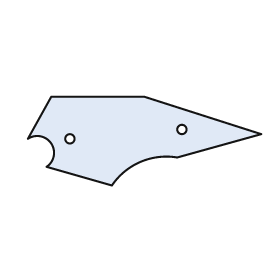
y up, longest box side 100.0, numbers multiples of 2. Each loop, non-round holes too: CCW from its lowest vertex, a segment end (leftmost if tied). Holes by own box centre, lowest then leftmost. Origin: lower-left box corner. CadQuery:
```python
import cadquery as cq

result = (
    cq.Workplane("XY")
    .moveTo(36.0, 0.0)
    .threePointArc((48.0, 10.0), (64.0, 12.0))
    .lineTo(100.0, 22.0)
    .lineTo(50.0, 38.0)
    .lineTo(10.0, 38.0)
    .lineTo(0.0, 20.0)
    .threePointArc((10.0, 18.0), (8.0, 8.0))
    .close()
    .moveTo(18.0, 20.0)
    .circle(2.0)
    .moveTo(66.0, 24.0)
    .circle(2.0)
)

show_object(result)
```